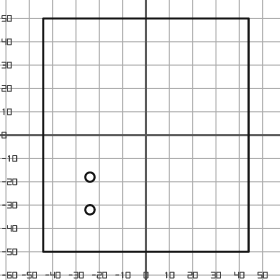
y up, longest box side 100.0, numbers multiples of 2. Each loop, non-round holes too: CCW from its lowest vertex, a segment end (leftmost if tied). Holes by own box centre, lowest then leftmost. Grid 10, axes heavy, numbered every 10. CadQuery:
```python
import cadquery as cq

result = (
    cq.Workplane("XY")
    .moveTo(-44.0, -50.0)
    .lineTo(44.0, -50.0)
    .lineTo(44.0, 50.0)
    .lineTo(-44.0, 50.0)
    .close()
    .moveTo(-24.0, -32.0)
    .circle(2.0)
    .moveTo(-24.0, -18.0)
    .circle(2.0)
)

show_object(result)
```